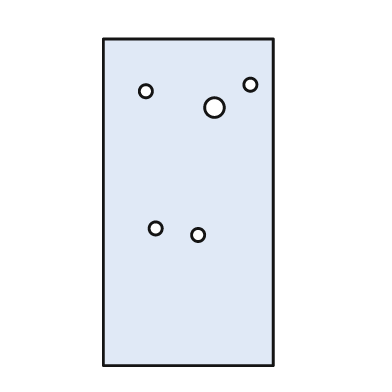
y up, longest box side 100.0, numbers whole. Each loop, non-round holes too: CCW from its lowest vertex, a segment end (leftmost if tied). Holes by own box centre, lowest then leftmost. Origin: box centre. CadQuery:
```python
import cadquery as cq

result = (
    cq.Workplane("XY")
    .moveTo(-26.0, -50.0)
    .lineTo(26.0, -50.0)
    .lineTo(26.0, 50.0)
    .lineTo(-26.0, 50.0)
    .close()
    .moveTo(3.0, -10.0)
    .circle(2.0)
    .moveTo(-10.0, -8.0)
    .circle(2.0)
    .moveTo(8.0, 29.0)
    .circle(3.0)
    .moveTo(-13.0, 34.0)
    .circle(2.0)
    .moveTo(19.0, 36.0)
    .circle(2.0)
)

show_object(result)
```